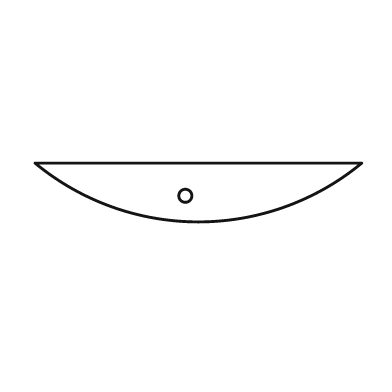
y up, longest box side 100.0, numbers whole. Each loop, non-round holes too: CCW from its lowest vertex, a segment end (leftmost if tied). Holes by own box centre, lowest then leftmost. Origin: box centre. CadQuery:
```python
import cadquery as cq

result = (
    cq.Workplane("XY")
    .moveTo(-50.0, 9.0)
    .threePointArc((0.0, -9.0), (50.0, 9.0))
    .close()
    .moveTo(-4.0, -1.0)
    .circle(2.0)
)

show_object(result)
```